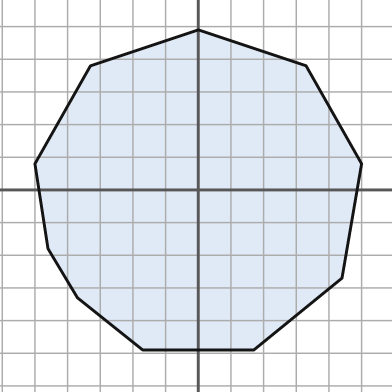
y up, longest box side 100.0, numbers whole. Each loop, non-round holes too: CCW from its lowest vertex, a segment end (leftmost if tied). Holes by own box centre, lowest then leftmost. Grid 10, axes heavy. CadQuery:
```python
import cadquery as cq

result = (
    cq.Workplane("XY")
    .moveTo(-17.0, -49.0)
    .lineTo(17.0, -49.0)
    .lineTo(44.0, -27.0)
    .lineTo(50.0, 8.0)
    .lineTo(33.0, 38.0)
    .lineTo(0.0, 49.0)
    .lineTo(-33.0, 38.0)
    .lineTo(-50.0, 8.0)
    .lineTo(-46.0, -18.0)
    .lineTo(-37.0, -33.0)
    .close()
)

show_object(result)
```